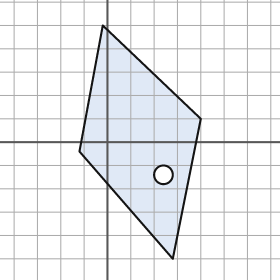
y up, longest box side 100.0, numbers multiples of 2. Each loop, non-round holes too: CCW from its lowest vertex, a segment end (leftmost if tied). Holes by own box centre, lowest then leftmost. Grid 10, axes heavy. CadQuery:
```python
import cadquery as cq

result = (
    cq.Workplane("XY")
    .moveTo(28.0, -50.0)
    .lineTo(40.0, 10.0)
    .lineTo(-2.0, 50.0)
    .lineTo(-12.0, -4.0)
    .close()
    .moveTo(24.0, -14.0)
    .circle(4.0)
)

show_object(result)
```